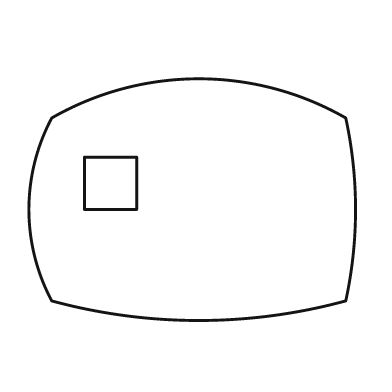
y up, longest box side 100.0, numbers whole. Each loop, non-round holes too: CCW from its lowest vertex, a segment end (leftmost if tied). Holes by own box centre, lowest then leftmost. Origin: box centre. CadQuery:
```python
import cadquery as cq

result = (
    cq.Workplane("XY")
    .moveTo(-43.0, -31.0)
    .threePointArc((2.0, -37.0), (47.0, -31.0))
    .threePointArc((50.0, -3.0), (47.0, 25.0))
    .threePointArc((2.0, 37.0), (-43.0, 25.0))
    .threePointArc((-50.0, -3.0), (-43.0, -31.0))
    .close()
    .moveTo(-33.0, -3.0)
    .lineTo(-17.0, -3.0)
    .lineTo(-17.0, 13.0)
    .lineTo(-33.0, 13.0)
    .close()
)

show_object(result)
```